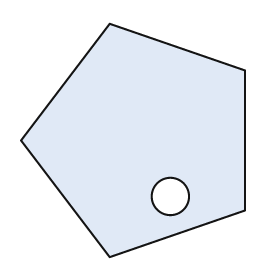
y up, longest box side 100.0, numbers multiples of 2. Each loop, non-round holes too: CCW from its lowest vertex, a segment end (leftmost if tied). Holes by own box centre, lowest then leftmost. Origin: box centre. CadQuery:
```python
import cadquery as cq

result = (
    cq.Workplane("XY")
    .moveTo(-10.0, -50.0)
    .lineTo(48.0, -30.0)
    .lineTo(48.0, 30.0)
    .lineTo(-10.0, 50.0)
    .lineTo(-48.0, 0.0)
    .close()
    .moveTo(16.0, -24.0)
    .circle(8.0)
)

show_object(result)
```